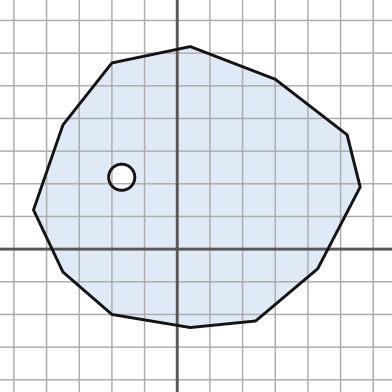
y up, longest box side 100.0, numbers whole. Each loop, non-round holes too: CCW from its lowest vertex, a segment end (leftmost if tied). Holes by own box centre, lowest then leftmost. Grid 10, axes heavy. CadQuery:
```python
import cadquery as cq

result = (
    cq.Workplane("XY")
    .moveTo(4.0, -24.0)
    .lineTo(24.0, -22.0)
    .lineTo(43.0, -6.0)
    .lineTo(56.0, 19.0)
    .lineTo(52.0, 35.0)
    .lineTo(30.0, 52.0)
    .lineTo(4.0, 62.0)
    .lineTo(-20.0, 57.0)
    .lineTo(-35.0, 38.0)
    .lineTo(-44.0, 12.0)
    .lineTo(-35.0, -7.0)
    .lineTo(-20.0, -20.0)
    .close()
    .moveTo(-17.0, 22.0)
    .circle(4.0)
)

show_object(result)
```